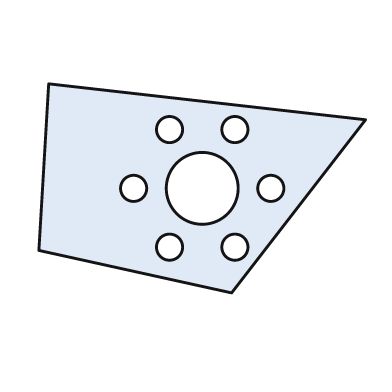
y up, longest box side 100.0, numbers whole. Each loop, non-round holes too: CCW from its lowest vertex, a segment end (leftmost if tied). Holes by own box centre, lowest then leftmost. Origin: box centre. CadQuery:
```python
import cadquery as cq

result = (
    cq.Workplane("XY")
    .moveTo(9.0, -32.0)
    .lineTo(50.0, 21.0)
    .lineTo(-47.0, 32.0)
    .lineTo(-50.0, -19.0)
    .close()
    .moveTo(-10.0, -18.0)
    .circle(4.0)
    .moveTo(10.0, -18.0)
    .circle(4.0)
    .moveTo(-21.0, 0.0)
    .circle(4.0)
    .moveTo(0.0, 0.0)
    .circle(11.0)
    .moveTo(21.0, 0.0)
    .circle(4.0)
    .moveTo(-10.0, 18.0)
    .circle(4.0)
    .moveTo(10.0, 18.0)
    .circle(4.0)
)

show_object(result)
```